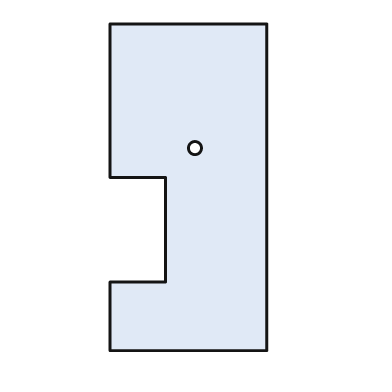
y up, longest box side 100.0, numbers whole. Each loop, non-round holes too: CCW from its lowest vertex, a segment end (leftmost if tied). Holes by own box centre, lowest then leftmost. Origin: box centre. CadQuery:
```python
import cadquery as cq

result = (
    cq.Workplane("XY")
    .moveTo(-24.0, -50.0)
    .lineTo(24.0, -50.0)
    .lineTo(24.0, 50.0)
    .lineTo(-24.0, 50.0)
    .lineTo(-24.0, 3.0)
    .lineTo(-7.0, 3.0)
    .lineTo(-7.0, -29.0)
    .lineTo(-24.0, -29.0)
    .close()
    .moveTo(2.0, 12.0)
    .circle(2.0)
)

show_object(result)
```